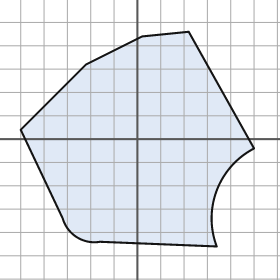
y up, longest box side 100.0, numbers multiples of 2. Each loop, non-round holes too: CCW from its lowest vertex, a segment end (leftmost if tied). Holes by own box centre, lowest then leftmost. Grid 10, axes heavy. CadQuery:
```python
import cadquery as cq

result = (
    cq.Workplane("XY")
    .moveTo(34.0, -46.0)
    .threePointArc((34.0, -22.0), (50.0, -4.0))
    .lineTo(22.0, 46.0)
    .lineTo(2.0, 44.0)
    .lineTo(-22.0, 32.0)
    .lineTo(-50.0, 4.0)
    .lineTo(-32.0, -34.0)
    .threePointArc((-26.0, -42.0), (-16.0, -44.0))
    .close()
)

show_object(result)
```